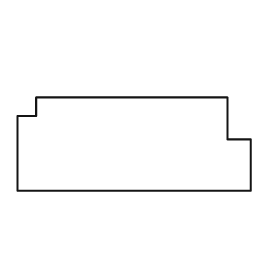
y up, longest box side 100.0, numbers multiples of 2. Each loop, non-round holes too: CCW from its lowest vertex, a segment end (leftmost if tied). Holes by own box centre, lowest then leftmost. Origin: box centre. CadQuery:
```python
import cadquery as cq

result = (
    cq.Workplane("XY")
    .moveTo(-50.0, -20.0)
    .lineTo(50.0, -20.0)
    .lineTo(50.0, 2.0)
    .lineTo(40.0, 2.0)
    .lineTo(40.0, 20.0)
    .lineTo(-42.0, 20.0)
    .lineTo(-42.0, 12.0)
    .lineTo(-50.0, 12.0)
    .close()
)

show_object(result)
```